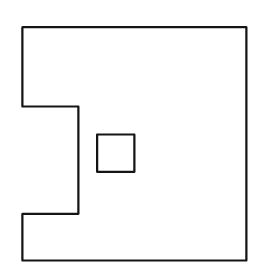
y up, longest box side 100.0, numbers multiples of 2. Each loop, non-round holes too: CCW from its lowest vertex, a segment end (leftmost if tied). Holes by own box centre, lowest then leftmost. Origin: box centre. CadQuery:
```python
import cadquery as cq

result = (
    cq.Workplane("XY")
    .moveTo(-48.0, -50.0)
    .lineTo(48.0, -50.0)
    .lineTo(48.0, 50.0)
    .lineTo(-48.0, 50.0)
    .lineTo(-48.0, 16.0)
    .lineTo(-24.0, 16.0)
    .lineTo(-24.0, -30.0)
    .lineTo(-48.0, -30.0)
    .close()
    .moveTo(-16.0, -12.0)
    .lineTo(0.0, -12.0)
    .lineTo(0.0, 4.0)
    .lineTo(-16.0, 4.0)
    .close()
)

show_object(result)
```